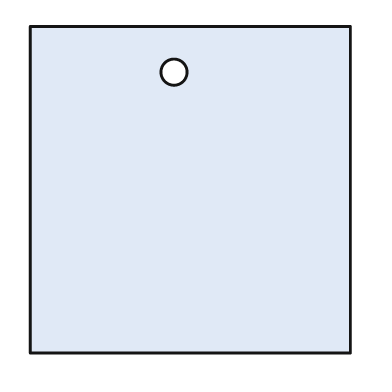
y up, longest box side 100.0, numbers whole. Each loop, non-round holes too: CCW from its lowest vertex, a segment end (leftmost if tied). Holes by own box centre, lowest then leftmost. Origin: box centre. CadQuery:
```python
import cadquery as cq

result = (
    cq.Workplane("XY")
    .moveTo(-49.0, -50.0)
    .lineTo(49.0, -50.0)
    .lineTo(49.0, 50.0)
    .lineTo(-49.0, 50.0)
    .close()
    .moveTo(-5.0, 36.0)
    .circle(4.0)
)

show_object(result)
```